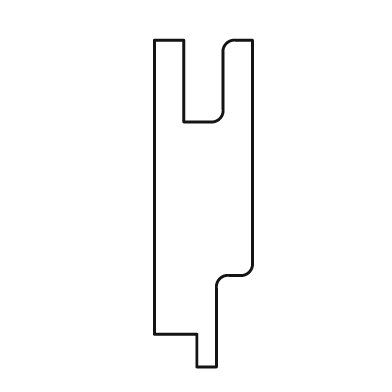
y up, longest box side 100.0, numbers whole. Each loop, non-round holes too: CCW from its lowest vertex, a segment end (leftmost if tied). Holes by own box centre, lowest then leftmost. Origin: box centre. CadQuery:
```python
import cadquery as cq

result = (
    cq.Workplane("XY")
    .moveTo(-2.0, -50.0)
    .lineTo(4.0, -50.0)
    .lineTo(4.0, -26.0)
    .threePointArc((5.0, -23.0), (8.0, -22.0))
    .lineTo(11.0, -22.0)
    .threePointArc((14.0, -21.0), (15.0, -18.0))
    .lineTo(15.0, 50.0)
    .lineTo(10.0, 50.0)
    .threePointArc((7.0, 49.0), (6.0, 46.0))
    .lineTo(6.0, 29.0)
    .threePointArc((5.0, 26.0), (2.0, 25.0))
    .lineTo(-6.0, 25.0)
    .lineTo(-6.0, 50.0)
    .lineTo(-15.0, 50.0)
    .lineTo(-15.0, -40.0)
    .lineTo(-2.0, -40.0)
    .close()
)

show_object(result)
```